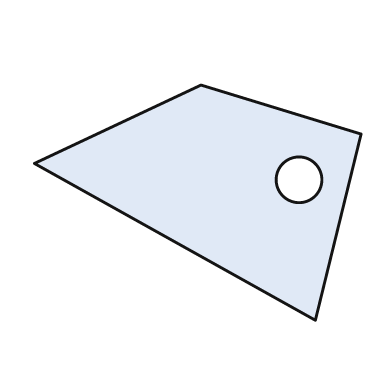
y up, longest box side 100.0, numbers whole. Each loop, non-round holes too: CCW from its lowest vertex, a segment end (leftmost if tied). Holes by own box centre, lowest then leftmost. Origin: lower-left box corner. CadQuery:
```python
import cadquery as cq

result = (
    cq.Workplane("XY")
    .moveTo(86.0, 0.0)
    .lineTo(100.0, 57.0)
    .lineTo(51.0, 72.0)
    .lineTo(0.0, 48.0)
    .close()
    .moveTo(81.0, 43.0)
    .circle(7.0)
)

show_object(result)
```